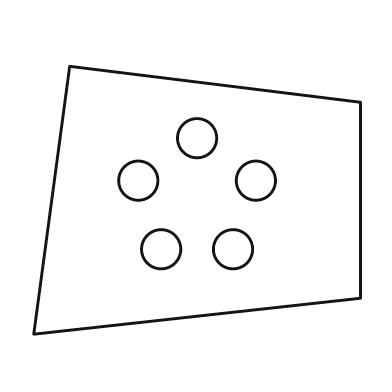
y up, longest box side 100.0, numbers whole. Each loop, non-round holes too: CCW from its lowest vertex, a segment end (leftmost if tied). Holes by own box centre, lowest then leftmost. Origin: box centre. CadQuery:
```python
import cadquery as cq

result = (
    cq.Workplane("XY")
    .moveTo(-50.0, -41.0)
    .lineTo(50.0, -30.0)
    .lineTo(50.0, 30.0)
    .lineTo(-39.0, 41.0)
    .close()
    .moveTo(-11.0, -15.0)
    .circle(6.0)
    .moveTo(11.0, -15.0)
    .circle(6.0)
    .moveTo(-18.0, 6.0)
    .circle(6.0)
    .moveTo(18.0, 6.0)
    .circle(6.0)
    .moveTo(0.0, 19.0)
    .circle(6.0)
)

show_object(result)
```